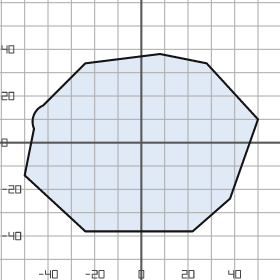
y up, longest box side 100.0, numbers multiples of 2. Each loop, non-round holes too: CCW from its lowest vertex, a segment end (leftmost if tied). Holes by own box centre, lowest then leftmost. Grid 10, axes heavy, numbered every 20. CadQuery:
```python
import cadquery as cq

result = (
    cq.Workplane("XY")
    .moveTo(-24.0, -38.0)
    .lineTo(22.0, -38.0)
    .lineTo(38.0, -24.0)
    .lineTo(50.0, 10.0)
    .lineTo(28.0, 34.0)
    .lineTo(8.0, 38.0)
    .lineTo(-24.0, 34.0)
    .lineTo(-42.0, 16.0)
    .threePointArc((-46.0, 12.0), (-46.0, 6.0))
    .lineTo(-50.0, -14.0)
    .close()
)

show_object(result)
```